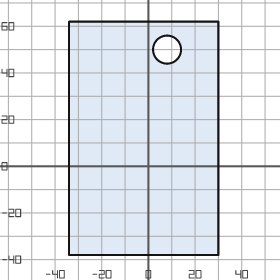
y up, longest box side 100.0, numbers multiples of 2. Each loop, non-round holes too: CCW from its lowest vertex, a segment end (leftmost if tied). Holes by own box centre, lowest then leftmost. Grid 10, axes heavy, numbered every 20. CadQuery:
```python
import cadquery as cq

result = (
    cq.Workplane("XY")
    .moveTo(-34.0, -38.0)
    .lineTo(30.0, -38.0)
    .lineTo(30.0, 62.0)
    .lineTo(-34.0, 62.0)
    .close()
    .moveTo(8.0, 50.0)
    .circle(6.0)
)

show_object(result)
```